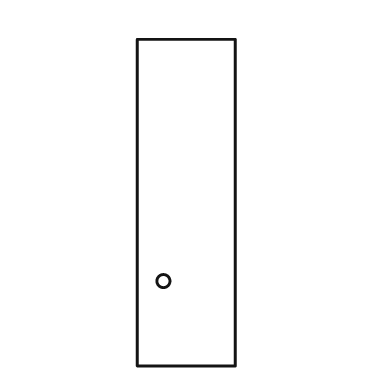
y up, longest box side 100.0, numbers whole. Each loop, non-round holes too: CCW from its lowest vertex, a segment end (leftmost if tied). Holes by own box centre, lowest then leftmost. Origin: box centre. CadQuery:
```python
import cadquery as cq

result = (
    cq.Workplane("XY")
    .moveTo(-15.0, -50.0)
    .lineTo(15.0, -50.0)
    .lineTo(15.0, 50.0)
    .lineTo(-15.0, 50.0)
    .close()
    .moveTo(-7.0, -24.0)
    .circle(2.0)
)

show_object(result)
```